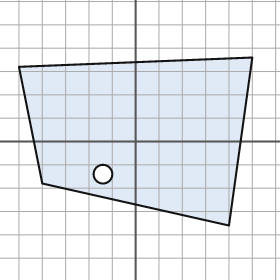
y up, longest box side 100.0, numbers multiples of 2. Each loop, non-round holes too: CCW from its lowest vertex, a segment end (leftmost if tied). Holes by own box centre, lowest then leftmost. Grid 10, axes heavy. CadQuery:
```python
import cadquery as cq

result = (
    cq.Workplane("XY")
    .moveTo(40.0, -36.0)
    .lineTo(50.0, 36.0)
    .lineTo(-50.0, 32.0)
    .lineTo(-40.0, -18.0)
    .close()
    .moveTo(-14.0, -14.0)
    .circle(4.0)
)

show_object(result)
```